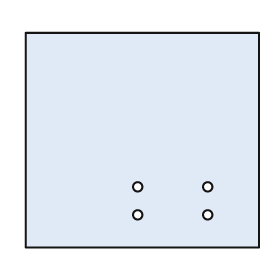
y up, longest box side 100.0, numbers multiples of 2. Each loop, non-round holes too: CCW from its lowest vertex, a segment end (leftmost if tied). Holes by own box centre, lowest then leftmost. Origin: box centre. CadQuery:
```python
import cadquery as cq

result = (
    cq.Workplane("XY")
    .moveTo(-50.0, -46.0)
    .lineTo(50.0, -46.0)
    .lineTo(50.0, 46.0)
    .lineTo(-50.0, 46.0)
    .close()
    .moveTo(-2.0, -32.0)
    .circle(2.0)
    .moveTo(28.0, -32.0)
    .circle(2.0)
    .moveTo(-2.0, -20.0)
    .circle(2.0)
    .moveTo(28.0, -20.0)
    .circle(2.0)
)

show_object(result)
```